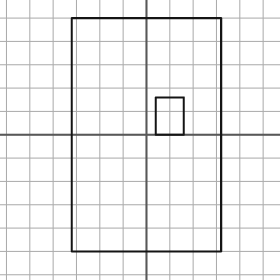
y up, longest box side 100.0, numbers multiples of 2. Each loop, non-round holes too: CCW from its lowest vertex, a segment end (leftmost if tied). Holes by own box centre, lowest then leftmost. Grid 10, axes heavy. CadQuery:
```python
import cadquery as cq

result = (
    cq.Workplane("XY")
    .moveTo(-32.0, -50.0)
    .lineTo(32.0, -50.0)
    .lineTo(32.0, 50.0)
    .lineTo(-32.0, 50.0)
    .close()
    .moveTo(4.0, 0.0)
    .lineTo(16.0, 0.0)
    .lineTo(16.0, 16.0)
    .lineTo(4.0, 16.0)
    .close()
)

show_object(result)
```